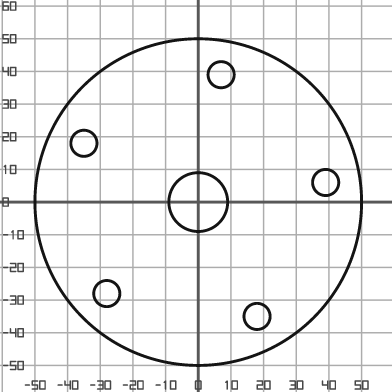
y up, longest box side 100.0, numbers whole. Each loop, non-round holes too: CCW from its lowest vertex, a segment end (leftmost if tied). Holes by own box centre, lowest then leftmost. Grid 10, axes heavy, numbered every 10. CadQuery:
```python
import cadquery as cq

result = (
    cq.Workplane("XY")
    .moveTo(0.0, 0.0)
    .circle(50.0)
    .moveTo(18.0, -35.0)
    .circle(4.0)
    .moveTo(-28.0, -28.0)
    .circle(4.0)
    .moveTo(0.0, 0.0)
    .circle(9.0)
    .moveTo(39.0, 6.0)
    .circle(4.0)
    .moveTo(-35.0, 18.0)
    .circle(4.0)
    .moveTo(7.0, 39.0)
    .circle(4.0)
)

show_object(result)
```